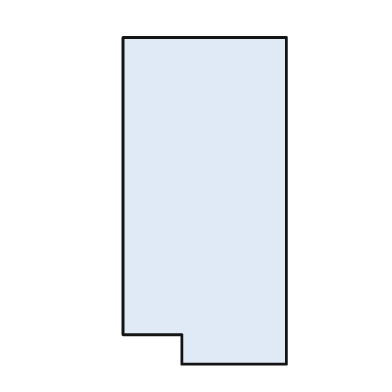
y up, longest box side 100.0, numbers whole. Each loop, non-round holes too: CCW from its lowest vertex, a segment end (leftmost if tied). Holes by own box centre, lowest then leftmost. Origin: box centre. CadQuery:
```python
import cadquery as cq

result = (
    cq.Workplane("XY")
    .moveTo(-7.0, -50.0)
    .lineTo(25.0, -50.0)
    .lineTo(25.0, 50.0)
    .lineTo(-25.0, 50.0)
    .lineTo(-25.0, -41.0)
    .lineTo(-7.0, -41.0)
    .close()
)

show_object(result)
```